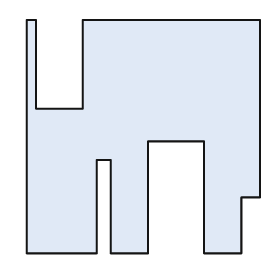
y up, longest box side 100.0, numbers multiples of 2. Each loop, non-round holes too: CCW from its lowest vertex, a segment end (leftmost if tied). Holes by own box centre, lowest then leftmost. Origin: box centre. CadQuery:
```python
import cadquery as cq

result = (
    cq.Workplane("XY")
    .moveTo(-50.0, -50.0)
    .lineTo(-20.0, -50.0)
    .lineTo(-20.0, -10.0)
    .lineTo(-14.0, -10.0)
    .lineTo(-14.0, -50.0)
    .lineTo(2.0, -50.0)
    .lineTo(2.0, -2.0)
    .lineTo(26.0, -2.0)
    .lineTo(26.0, -50.0)
    .lineTo(42.0, -50.0)
    .lineTo(42.0, -26.0)
    .lineTo(50.0, -26.0)
    .lineTo(50.0, 50.0)
    .lineTo(-26.0, 50.0)
    .lineTo(-26.0, 12.0)
    .lineTo(-46.0, 12.0)
    .lineTo(-46.0, 50.0)
    .lineTo(-50.0, 50.0)
    .close()
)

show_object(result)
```